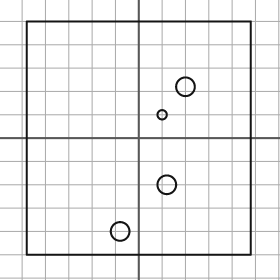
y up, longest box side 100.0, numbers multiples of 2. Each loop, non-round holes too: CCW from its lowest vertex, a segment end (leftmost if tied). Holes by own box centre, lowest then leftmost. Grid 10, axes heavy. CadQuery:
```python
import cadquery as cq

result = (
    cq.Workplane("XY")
    .moveTo(-48.0, -50.0)
    .lineTo(48.0, -50.0)
    .lineTo(48.0, 50.0)
    .lineTo(-48.0, 50.0)
    .close()
    .moveTo(-8.0, -40.0)
    .circle(4.0)
    .moveTo(12.0, -20.0)
    .circle(4.0)
    .moveTo(10.0, 10.0)
    .circle(2.0)
    .moveTo(20.0, 22.0)
    .circle(4.0)
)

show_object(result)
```